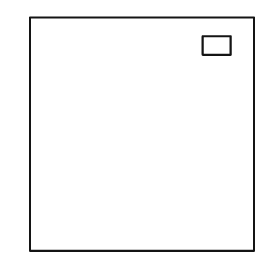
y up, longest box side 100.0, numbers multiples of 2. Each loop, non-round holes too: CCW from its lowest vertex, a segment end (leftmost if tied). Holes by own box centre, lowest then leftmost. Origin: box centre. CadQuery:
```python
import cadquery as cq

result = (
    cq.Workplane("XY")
    .moveTo(-48.0, -50.0)
    .lineTo(48.0, -50.0)
    .lineTo(48.0, 50.0)
    .lineTo(-48.0, 50.0)
    .close()
    .moveTo(26.0, 34.0)
    .lineTo(38.0, 34.0)
    .lineTo(38.0, 42.0)
    .lineTo(26.0, 42.0)
    .close()
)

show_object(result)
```